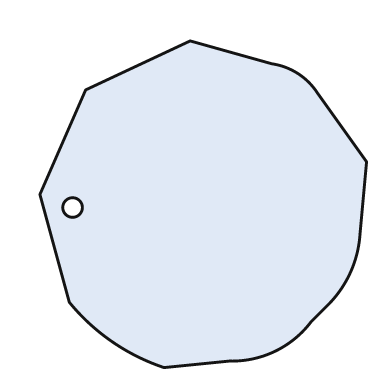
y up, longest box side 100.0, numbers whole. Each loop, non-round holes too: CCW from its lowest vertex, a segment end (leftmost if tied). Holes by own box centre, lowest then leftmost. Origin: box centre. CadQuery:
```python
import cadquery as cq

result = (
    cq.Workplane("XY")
    .moveTo(-12.0, -50.0)
    .lineTo(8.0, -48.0)
    .threePointArc((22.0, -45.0), (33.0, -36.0))
    .lineTo(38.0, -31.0)
    .threePointArc((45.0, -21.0), (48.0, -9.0))
    .lineTo(50.0, 13.0)
    .lineTo(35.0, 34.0)
    .threePointArc((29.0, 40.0), (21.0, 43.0))
    .lineTo(-4.0, 50.0)
    .lineTo(-36.0, 35.0)
    .lineTo(-50.0, 3.0)
    .lineTo(-41.0, -30.0)
    .threePointArc((-28.0, -42.0), (-12.0, -50.0))
    .close()
    .moveTo(-40.0, -1.0)
    .circle(3.0)
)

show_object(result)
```